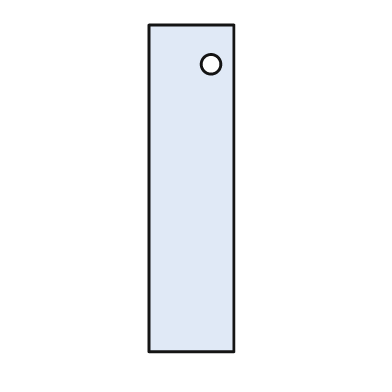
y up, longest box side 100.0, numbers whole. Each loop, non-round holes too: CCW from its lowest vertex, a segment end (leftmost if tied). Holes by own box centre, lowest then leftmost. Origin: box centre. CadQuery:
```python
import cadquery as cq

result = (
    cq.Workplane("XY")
    .moveTo(-13.0, -50.0)
    .lineTo(13.0, -50.0)
    .lineTo(13.0, 50.0)
    .lineTo(-13.0, 50.0)
    .close()
    .moveTo(6.0, 38.0)
    .circle(3.0)
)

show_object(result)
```